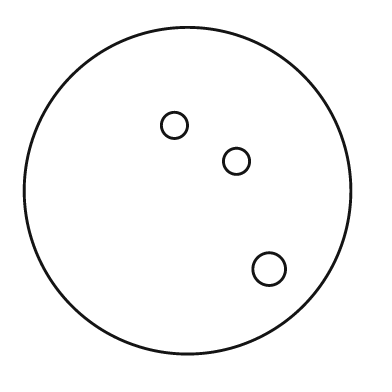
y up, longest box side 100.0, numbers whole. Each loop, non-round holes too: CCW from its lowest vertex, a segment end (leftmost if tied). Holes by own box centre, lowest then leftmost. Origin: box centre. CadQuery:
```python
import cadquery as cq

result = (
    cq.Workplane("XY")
    .moveTo(0.0, 0.0)
    .circle(50.0)
    .moveTo(25.0, -24.0)
    .circle(5.0)
    .moveTo(15.0, 9.0)
    .circle(4.0)
    .moveTo(-4.0, 20.0)
    .circle(4.0)
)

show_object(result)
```